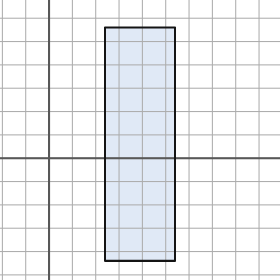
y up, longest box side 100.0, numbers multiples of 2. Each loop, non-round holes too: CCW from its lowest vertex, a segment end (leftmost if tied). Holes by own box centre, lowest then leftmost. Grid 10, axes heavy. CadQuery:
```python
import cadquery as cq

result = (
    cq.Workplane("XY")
    .moveTo(24.0, -44.0)
    .lineTo(54.0, -44.0)
    .lineTo(54.0, 56.0)
    .lineTo(24.0, 56.0)
    .close()
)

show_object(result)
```